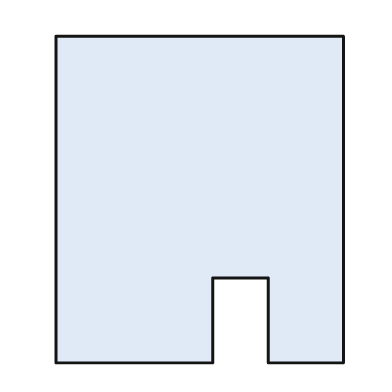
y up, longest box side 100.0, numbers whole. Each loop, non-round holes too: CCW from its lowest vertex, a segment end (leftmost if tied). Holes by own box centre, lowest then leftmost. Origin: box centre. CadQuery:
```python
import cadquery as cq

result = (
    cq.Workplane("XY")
    .moveTo(-44.0, -50.0)
    .lineTo(4.0, -50.0)
    .lineTo(4.0, -24.0)
    .lineTo(21.0, -24.0)
    .lineTo(21.0, -50.0)
    .lineTo(44.0, -50.0)
    .lineTo(44.0, 50.0)
    .lineTo(-44.0, 50.0)
    .close()
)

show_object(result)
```